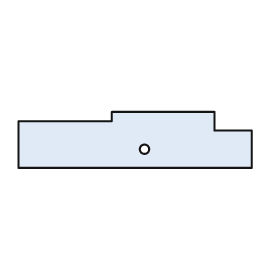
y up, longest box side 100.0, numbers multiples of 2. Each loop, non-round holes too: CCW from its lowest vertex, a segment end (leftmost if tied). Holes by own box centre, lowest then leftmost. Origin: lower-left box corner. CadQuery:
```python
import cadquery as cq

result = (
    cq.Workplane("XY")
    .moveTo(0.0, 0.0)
    .lineTo(100.0, 0.0)
    .lineTo(100.0, 16.0)
    .lineTo(84.0, 16.0)
    .lineTo(84.0, 24.0)
    .lineTo(40.0, 24.0)
    .lineTo(40.0, 20.0)
    .lineTo(0.0, 20.0)
    .close()
    .moveTo(54.0, 8.0)
    .circle(2.0)
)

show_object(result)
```